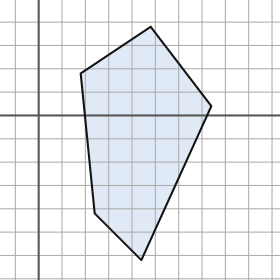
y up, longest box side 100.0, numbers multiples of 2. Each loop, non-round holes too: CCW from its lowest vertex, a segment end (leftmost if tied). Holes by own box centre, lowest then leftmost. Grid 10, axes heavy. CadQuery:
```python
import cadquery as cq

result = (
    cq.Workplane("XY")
    .moveTo(44.0, -62.0)
    .lineTo(74.0, 4.0)
    .lineTo(48.0, 38.0)
    .lineTo(18.0, 18.0)
    .lineTo(24.0, -42.0)
    .close()
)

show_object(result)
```